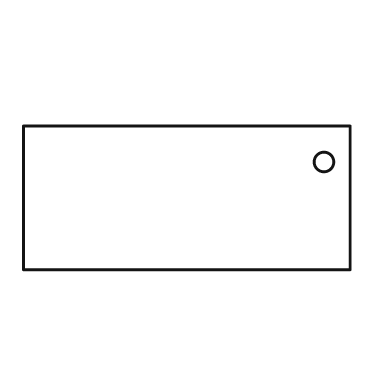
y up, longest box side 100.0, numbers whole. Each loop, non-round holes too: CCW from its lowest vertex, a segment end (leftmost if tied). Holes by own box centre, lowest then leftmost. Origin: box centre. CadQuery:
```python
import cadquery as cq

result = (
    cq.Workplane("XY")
    .moveTo(-50.0, -22.0)
    .lineTo(50.0, -22.0)
    .lineTo(50.0, 22.0)
    .lineTo(-50.0, 22.0)
    .close()
    .moveTo(42.0, 11.0)
    .circle(3.0)
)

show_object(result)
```